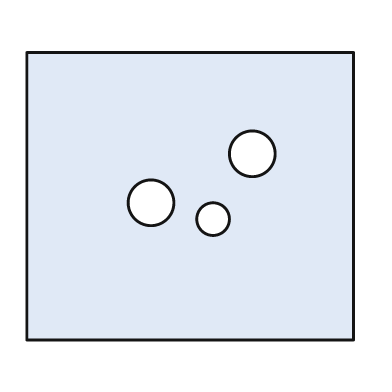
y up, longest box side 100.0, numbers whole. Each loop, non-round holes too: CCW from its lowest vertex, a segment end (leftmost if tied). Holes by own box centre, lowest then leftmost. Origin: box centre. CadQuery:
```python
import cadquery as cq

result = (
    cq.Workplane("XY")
    .moveTo(-50.0, -44.0)
    .lineTo(50.0, -44.0)
    .lineTo(50.0, 44.0)
    .lineTo(-50.0, 44.0)
    .close()
    .moveTo(7.0, -7.0)
    .circle(5.0)
    .moveTo(-12.0, -2.0)
    .circle(7.0)
    .moveTo(19.0, 13.0)
    .circle(7.0)
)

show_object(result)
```